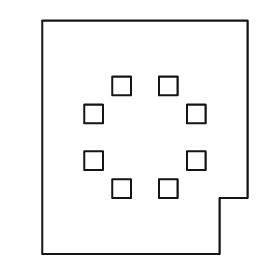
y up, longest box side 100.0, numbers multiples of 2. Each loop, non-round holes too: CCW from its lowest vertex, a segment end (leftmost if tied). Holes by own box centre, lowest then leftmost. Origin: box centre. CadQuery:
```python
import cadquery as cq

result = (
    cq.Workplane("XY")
    .moveTo(-44.0, -50.0)
    .lineTo(32.0, -50.0)
    .lineTo(32.0, -26.0)
    .lineTo(44.0, -26.0)
    .lineTo(44.0, 50.0)
    .lineTo(-44.0, 50.0)
    .close()
    .moveTo(-14.0, -26.0)
    .lineTo(-6.0, -26.0)
    .lineTo(-6.0, -18.0)
    .lineTo(-14.0, -18.0)
    .close()
    .moveTo(6.0, -26.0)
    .lineTo(14.0, -26.0)
    .lineTo(14.0, -18.0)
    .lineTo(6.0, -18.0)
    .close()
    .moveTo(-26.0, -14.0)
    .lineTo(-18.0, -14.0)
    .lineTo(-18.0, -6.0)
    .lineTo(-26.0, -6.0)
    .close()
    .moveTo(18.0, -14.0)
    .lineTo(26.0, -14.0)
    .lineTo(26.0, -6.0)
    .lineTo(18.0, -6.0)
    .close()
    .moveTo(-26.0, 6.0)
    .lineTo(-18.0, 6.0)
    .lineTo(-18.0, 14.0)
    .lineTo(-26.0, 14.0)
    .close()
    .moveTo(18.0, 6.0)
    .lineTo(26.0, 6.0)
    .lineTo(26.0, 14.0)
    .lineTo(18.0, 14.0)
    .close()
    .moveTo(-14.0, 18.0)
    .lineTo(-6.0, 18.0)
    .lineTo(-6.0, 26.0)
    .lineTo(-14.0, 26.0)
    .close()
    .moveTo(6.0, 18.0)
    .lineTo(14.0, 18.0)
    .lineTo(14.0, 26.0)
    .lineTo(6.0, 26.0)
    .close()
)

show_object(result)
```